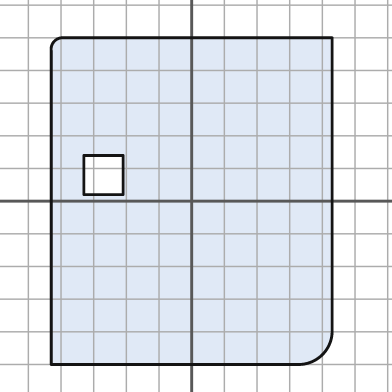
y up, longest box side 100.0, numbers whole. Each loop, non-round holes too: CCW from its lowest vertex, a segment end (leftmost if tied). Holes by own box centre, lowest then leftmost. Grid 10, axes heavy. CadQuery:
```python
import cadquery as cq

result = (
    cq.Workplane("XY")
    .moveTo(-43.0, -50.0)
    .lineTo(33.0, -50.0)
    .threePointArc((40.0, -47.0), (43.0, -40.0))
    .lineTo(43.0, 50.0)
    .lineTo(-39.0, 50.0)
    .threePointArc((-42.0, 49.0), (-43.0, 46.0))
    .close()
    .moveTo(-33.0, 2.0)
    .lineTo(-21.0, 2.0)
    .lineTo(-21.0, 14.0)
    .lineTo(-33.0, 14.0)
    .close()
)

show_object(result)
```